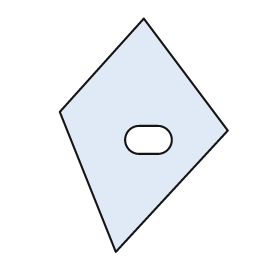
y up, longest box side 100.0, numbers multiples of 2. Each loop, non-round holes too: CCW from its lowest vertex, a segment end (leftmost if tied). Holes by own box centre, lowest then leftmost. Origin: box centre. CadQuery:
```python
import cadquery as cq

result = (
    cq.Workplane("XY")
    .moveTo(-12.0, -50.0)
    .lineTo(36.0, 2.0)
    .lineTo(0.0, 50.0)
    .lineTo(-36.0, 10.0)
    .close()
    .moveTo(-2.0, -8.0)
    .lineTo(6.0, -8.0)
    .threePointArc((12.0, -2.0), (6.0, 4.0))
    .lineTo(-2.0, 4.0)
    .threePointArc((-8.0, -2.0), (-2.0, -8.0))
    .close()
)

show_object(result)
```